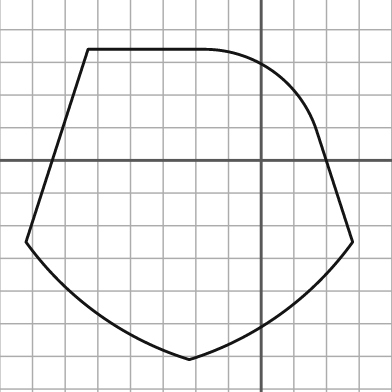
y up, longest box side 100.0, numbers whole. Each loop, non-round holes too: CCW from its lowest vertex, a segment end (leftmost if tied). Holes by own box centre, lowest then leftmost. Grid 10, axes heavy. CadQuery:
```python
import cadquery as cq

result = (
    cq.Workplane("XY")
    .moveTo(-22.0, -61.0)
    .threePointArc((6.0, -47.0), (28.0, -25.0))
    .lineTo(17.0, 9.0)
    .threePointArc((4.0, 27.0), (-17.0, 34.0))
    .lineTo(-53.0, 34.0)
    .lineTo(-72.0, -25.0)
    .threePointArc((-50.0, -47.0), (-22.0, -61.0))
    .close()
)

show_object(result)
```